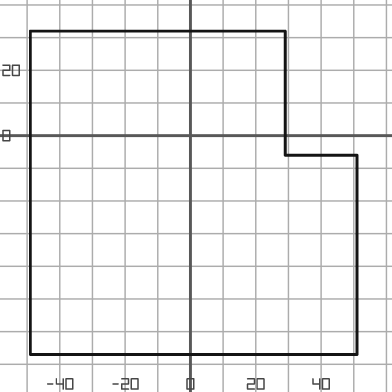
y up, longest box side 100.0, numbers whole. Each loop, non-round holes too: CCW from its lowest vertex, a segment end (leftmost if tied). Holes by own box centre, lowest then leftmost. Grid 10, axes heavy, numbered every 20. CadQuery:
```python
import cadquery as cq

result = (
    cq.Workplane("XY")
    .moveTo(-49.0, -67.0)
    .lineTo(51.0, -67.0)
    .lineTo(51.0, -6.0)
    .lineTo(29.0, -6.0)
    .lineTo(29.0, 32.0)
    .lineTo(-49.0, 32.0)
    .close()
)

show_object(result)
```